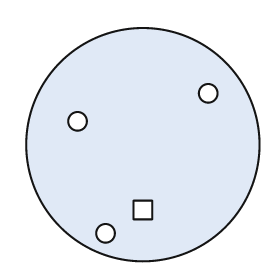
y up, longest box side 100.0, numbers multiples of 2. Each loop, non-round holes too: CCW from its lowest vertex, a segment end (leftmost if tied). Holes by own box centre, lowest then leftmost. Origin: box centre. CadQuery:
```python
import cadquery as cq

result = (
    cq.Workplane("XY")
    .moveTo(0.0, 0.0)
    .circle(50.0)
    .moveTo(-16.0, -38.0)
    .circle(4.0)
    .moveTo(-4.0, -32.0)
    .lineTo(4.0, -32.0)
    .lineTo(4.0, -24.0)
    .lineTo(-4.0, -24.0)
    .close()
    .moveTo(-28.0, 10.0)
    .circle(4.0)
    .moveTo(28.0, 22.0)
    .circle(4.0)
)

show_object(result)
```